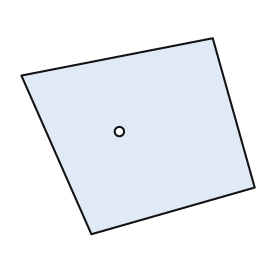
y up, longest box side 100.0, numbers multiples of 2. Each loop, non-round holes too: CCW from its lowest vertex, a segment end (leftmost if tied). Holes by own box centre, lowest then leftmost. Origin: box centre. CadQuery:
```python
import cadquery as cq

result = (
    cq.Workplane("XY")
    .moveTo(-20.0, -42.0)
    .lineTo(50.0, -22.0)
    .lineTo(32.0, 42.0)
    .lineTo(-50.0, 26.0)
    .close()
    .moveTo(-8.0, 2.0)
    .circle(2.0)
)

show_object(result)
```